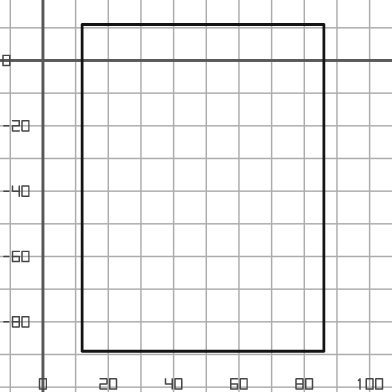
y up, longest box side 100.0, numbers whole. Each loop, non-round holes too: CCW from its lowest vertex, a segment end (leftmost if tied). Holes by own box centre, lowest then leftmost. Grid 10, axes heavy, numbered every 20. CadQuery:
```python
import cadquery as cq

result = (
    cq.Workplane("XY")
    .moveTo(12.0, -89.0)
    .lineTo(86.0, -89.0)
    .lineTo(86.0, 11.0)
    .lineTo(12.0, 11.0)
    .close()
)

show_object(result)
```